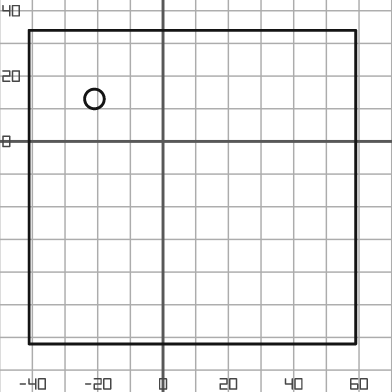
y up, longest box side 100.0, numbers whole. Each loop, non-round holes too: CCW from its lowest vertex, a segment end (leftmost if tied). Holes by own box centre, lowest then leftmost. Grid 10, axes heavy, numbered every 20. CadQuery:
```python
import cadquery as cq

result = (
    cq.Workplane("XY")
    .moveTo(-41.0, -62.0)
    .lineTo(59.0, -62.0)
    .lineTo(59.0, 34.0)
    .lineTo(-41.0, 34.0)
    .close()
    .moveTo(-21.0, 13.0)
    .circle(3.0)
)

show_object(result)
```